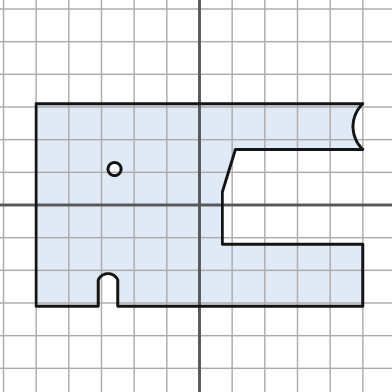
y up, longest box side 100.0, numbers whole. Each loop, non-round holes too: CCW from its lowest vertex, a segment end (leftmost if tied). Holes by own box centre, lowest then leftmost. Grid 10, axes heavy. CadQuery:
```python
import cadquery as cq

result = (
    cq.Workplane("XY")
    .moveTo(-50.0, -31.0)
    .lineTo(-31.0, -31.0)
    .lineTo(-31.0, -23.0)
    .threePointArc((-28.0, -21.0), (-25.0, -23.0))
    .lineTo(-25.0, -31.0)
    .lineTo(50.0, -31.0)
    .lineTo(50.0, -12.0)
    .lineTo(7.0, -12.0)
    .lineTo(7.0, 4.0)
    .lineTo(11.0, 17.0)
    .lineTo(50.0, 17.0)
    .threePointArc((47.0, 24.0), (50.0, 31.0))
    .lineTo(-50.0, 31.0)
    .close()
    .moveTo(-26.0, 11.0)
    .circle(2.0)
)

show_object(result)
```